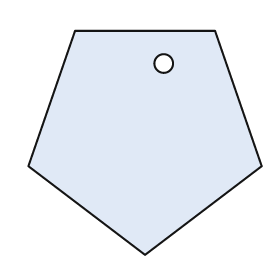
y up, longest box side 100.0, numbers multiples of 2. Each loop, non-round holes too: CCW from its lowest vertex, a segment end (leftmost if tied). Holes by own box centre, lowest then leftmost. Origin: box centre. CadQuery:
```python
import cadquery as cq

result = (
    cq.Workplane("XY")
    .moveTo(0.0, -48.0)
    .lineTo(50.0, -10.0)
    .lineTo(30.0, 48.0)
    .lineTo(-30.0, 48.0)
    .lineTo(-50.0, -10.0)
    .close()
    .moveTo(8.0, 34.0)
    .circle(4.0)
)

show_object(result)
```